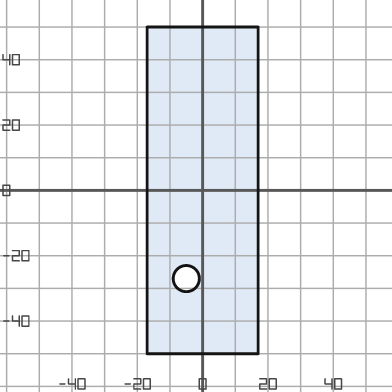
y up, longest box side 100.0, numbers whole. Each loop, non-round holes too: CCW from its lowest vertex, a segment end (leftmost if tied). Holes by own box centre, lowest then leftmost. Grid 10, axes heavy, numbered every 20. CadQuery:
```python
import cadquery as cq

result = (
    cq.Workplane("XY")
    .moveTo(-17.0, -50.0)
    .lineTo(17.0, -50.0)
    .lineTo(17.0, 50.0)
    .lineTo(-17.0, 50.0)
    .close()
    .moveTo(-5.0, -27.0)
    .circle(4.0)
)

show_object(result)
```